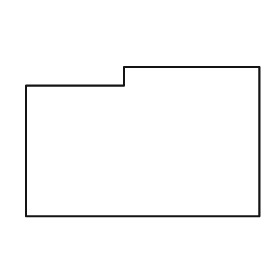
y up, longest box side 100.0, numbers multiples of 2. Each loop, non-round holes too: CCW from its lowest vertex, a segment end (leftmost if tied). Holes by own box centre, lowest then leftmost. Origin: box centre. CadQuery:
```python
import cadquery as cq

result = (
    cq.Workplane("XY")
    .moveTo(-50.0, -32.0)
    .lineTo(50.0, -32.0)
    .lineTo(50.0, 32.0)
    .lineTo(-8.0, 32.0)
    .lineTo(-8.0, 24.0)
    .lineTo(-50.0, 24.0)
    .close()
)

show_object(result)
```